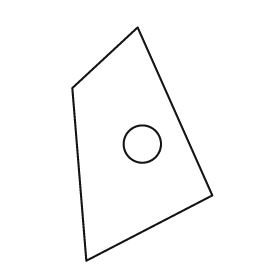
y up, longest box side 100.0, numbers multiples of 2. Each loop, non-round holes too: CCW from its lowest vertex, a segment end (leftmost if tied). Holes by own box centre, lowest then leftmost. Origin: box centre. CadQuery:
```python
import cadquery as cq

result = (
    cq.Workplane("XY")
    .moveTo(-24.0, -50.0)
    .lineTo(30.0, -22.0)
    .lineTo(-2.0, 50.0)
    .lineTo(-30.0, 24.0)
    .close()
    .moveTo(0.0, 0.0)
    .circle(8.0)
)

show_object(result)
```